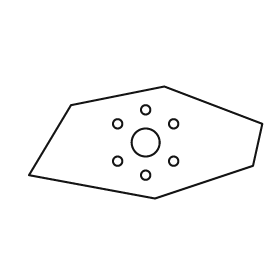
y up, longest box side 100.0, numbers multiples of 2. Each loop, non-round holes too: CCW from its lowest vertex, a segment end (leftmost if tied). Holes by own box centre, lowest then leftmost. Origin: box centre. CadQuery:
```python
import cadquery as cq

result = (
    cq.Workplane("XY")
    .moveTo(4.0, -24.0)
    .lineTo(46.0, -10.0)
    .lineTo(50.0, 8.0)
    .lineTo(8.0, 24.0)
    .lineTo(-32.0, 16.0)
    .lineTo(-50.0, -14.0)
    .close()
    .moveTo(0.0, -14.0)
    .circle(2.0)
    .moveTo(-12.0, -8.0)
    .circle(2.0)
    .moveTo(12.0, -8.0)
    .circle(2.0)
    .moveTo(0.0, 0.0)
    .circle(6.0)
    .moveTo(-12.0, 8.0)
    .circle(2.0)
    .moveTo(12.0, 8.0)
    .circle(2.0)
    .moveTo(0.0, 14.0)
    .circle(2.0)
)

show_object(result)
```